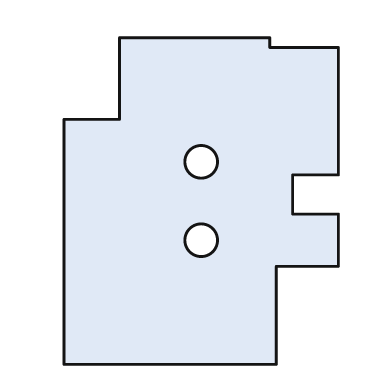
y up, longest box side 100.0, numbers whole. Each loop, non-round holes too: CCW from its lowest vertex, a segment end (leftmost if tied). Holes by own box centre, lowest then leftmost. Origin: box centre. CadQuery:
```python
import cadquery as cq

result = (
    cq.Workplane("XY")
    .moveTo(-42.0, -50.0)
    .lineTo(23.0, -50.0)
    .lineTo(23.0, -20.0)
    .lineTo(42.0, -20.0)
    .lineTo(42.0, -4.0)
    .lineTo(28.0, -4.0)
    .lineTo(28.0, 8.0)
    .lineTo(42.0, 8.0)
    .lineTo(42.0, 47.0)
    .lineTo(21.0, 47.0)
    .lineTo(21.0, 50.0)
    .lineTo(-25.0, 50.0)
    .lineTo(-25.0, 25.0)
    .lineTo(-42.0, 25.0)
    .close()
    .moveTo(0.0, -12.0)
    .circle(5.0)
    .moveTo(0.0, 12.0)
    .circle(5.0)
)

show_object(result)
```